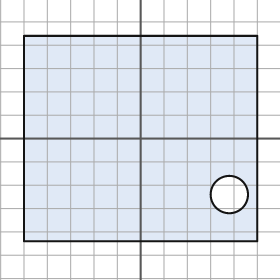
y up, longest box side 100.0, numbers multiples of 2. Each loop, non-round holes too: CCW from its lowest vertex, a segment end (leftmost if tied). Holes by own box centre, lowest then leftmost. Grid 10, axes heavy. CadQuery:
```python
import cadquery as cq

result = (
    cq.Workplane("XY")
    .moveTo(-50.0, -44.0)
    .lineTo(50.0, -44.0)
    .lineTo(50.0, 44.0)
    .lineTo(-50.0, 44.0)
    .close()
    .moveTo(38.0, -24.0)
    .circle(8.0)
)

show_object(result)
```